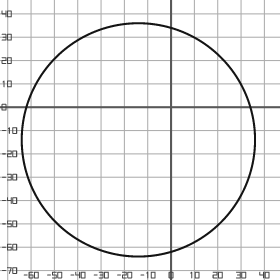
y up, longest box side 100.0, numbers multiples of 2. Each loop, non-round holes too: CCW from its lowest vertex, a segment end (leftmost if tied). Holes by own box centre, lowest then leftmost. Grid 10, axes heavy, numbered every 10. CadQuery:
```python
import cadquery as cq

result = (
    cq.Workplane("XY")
    .moveTo(-14.0, -14.0)
    .circle(50.0)
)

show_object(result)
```